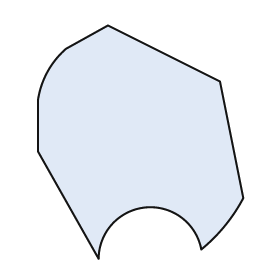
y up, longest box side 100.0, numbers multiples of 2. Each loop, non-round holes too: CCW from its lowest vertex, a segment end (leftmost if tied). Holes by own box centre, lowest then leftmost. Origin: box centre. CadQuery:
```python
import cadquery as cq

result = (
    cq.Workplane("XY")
    .moveTo(-18.0, -50.0)
    .threePointArc((2.0, -28.0), (26.0, -46.0))
    .threePointArc((36.0, -36.0), (44.0, -24.0))
    .lineTo(34.0, 26.0)
    .lineTo(-14.0, 50.0)
    .lineTo(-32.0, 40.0)
    .threePointArc((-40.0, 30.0), (-44.0, 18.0))
    .lineTo(-44.0, -4.0)
    .close()
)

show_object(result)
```